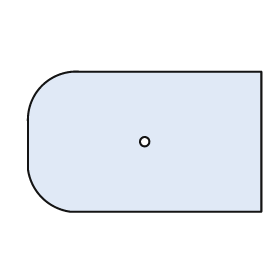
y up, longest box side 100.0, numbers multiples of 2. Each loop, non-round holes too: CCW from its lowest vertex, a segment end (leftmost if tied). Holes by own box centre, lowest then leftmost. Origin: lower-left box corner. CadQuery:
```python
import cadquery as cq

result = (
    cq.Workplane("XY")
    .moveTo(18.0, 0.0)
    .lineTo(100.0, 0.0)
    .lineTo(100.0, 60.0)
    .lineTo(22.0, 60.0)
    .threePointArc((6.0, 54.0), (0.0, 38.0))
    .lineTo(0.0, 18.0)
    .threePointArc((6.0, 6.0), (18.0, 0.0))
    .close()
    .moveTo(50.0, 30.0)
    .circle(2.0)
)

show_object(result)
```